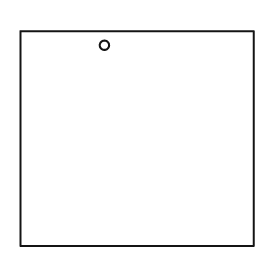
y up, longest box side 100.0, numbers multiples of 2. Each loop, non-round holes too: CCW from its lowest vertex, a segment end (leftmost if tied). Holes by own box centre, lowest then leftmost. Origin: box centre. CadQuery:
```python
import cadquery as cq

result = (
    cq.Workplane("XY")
    .moveTo(-50.0, -46.0)
    .lineTo(50.0, -46.0)
    .lineTo(50.0, 46.0)
    .lineTo(-50.0, 46.0)
    .close()
    .moveTo(-14.0, 40.0)
    .circle(2.0)
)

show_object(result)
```